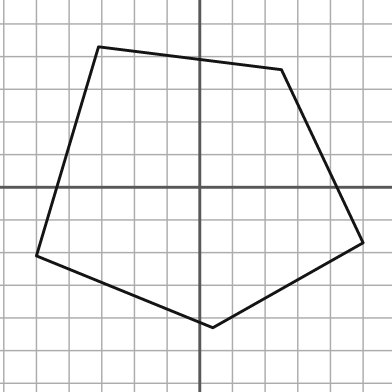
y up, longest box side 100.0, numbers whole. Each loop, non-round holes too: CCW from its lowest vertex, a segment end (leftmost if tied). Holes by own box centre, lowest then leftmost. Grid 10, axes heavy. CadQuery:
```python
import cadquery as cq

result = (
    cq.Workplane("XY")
    .moveTo(4.0, -43.0)
    .lineTo(50.0, -17.0)
    .lineTo(25.0, 36.0)
    .lineTo(-31.0, 43.0)
    .lineTo(-50.0, -21.0)
    .close()
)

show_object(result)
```